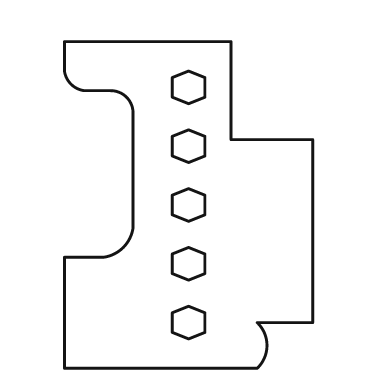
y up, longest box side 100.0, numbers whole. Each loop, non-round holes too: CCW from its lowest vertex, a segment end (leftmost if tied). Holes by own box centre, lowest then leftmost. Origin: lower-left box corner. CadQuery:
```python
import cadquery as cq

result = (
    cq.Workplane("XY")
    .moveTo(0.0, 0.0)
    .lineTo(59.0, 0.0)
    .threePointArc((62.0, 7.0), (59.0, 14.0))
    .lineTo(76.0, 14.0)
    .lineTo(76.0, 70.0)
    .lineTo(51.0, 70.0)
    .lineTo(51.0, 100.0)
    .lineTo(0.0, 100.0)
    .lineTo(0.0, 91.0)
    .threePointArc((2.0, 87.0), (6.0, 85.0))
    .lineTo(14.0, 85.0)
    .threePointArc((19.0, 83.0), (21.0, 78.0))
    .lineTo(21.0, 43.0)
    .threePointArc((18.0, 37.0), (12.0, 34.0))
    .lineTo(0.0, 34.0)
    .close()
    .moveTo(38.0, 9.0)
    .lineTo(43.0, 11.0)
    .lineTo(43.0, 17.0)
    .lineTo(38.0, 19.0)
    .lineTo(33.0, 17.0)
    .lineTo(33.0, 11.0)
    .close()
    .moveTo(38.0, 27.0)
    .lineTo(43.0, 29.0)
    .lineTo(43.0, 35.0)
    .lineTo(38.0, 37.0)
    .lineTo(33.0, 35.0)
    .lineTo(33.0, 29.0)
    .close()
    .moveTo(38.0, 45.0)
    .lineTo(43.0, 47.0)
    .lineTo(43.0, 53.0)
    .lineTo(38.0, 55.0)
    .lineTo(33.0, 53.0)
    .lineTo(33.0, 47.0)
    .close()
    .moveTo(38.0, 63.0)
    .lineTo(43.0, 65.0)
    .lineTo(43.0, 71.0)
    .lineTo(38.0, 73.0)
    .lineTo(33.0, 71.0)
    .lineTo(33.0, 65.0)
    .close()
    .moveTo(38.0, 81.0)
    .lineTo(43.0, 83.0)
    .lineTo(43.0, 89.0)
    .lineTo(38.0, 91.0)
    .lineTo(33.0, 89.0)
    .lineTo(33.0, 83.0)
    .close()
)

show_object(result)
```